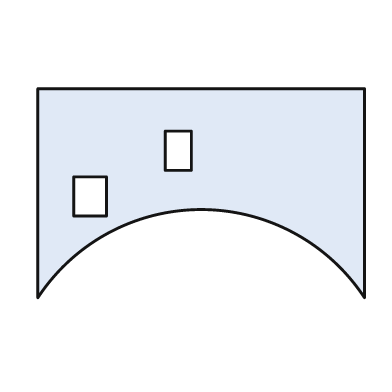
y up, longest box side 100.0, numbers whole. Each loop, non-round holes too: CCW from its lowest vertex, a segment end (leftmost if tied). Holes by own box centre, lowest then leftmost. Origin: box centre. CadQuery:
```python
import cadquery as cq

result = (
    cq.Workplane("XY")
    .moveTo(-50.0, -32.0)
    .threePointArc((0.0, -5.0), (50.0, -32.0))
    .lineTo(50.0, 32.0)
    .lineTo(-50.0, 32.0)
    .close()
    .moveTo(-39.0, -7.0)
    .lineTo(-29.0, -7.0)
    .lineTo(-29.0, 5.0)
    .lineTo(-39.0, 5.0)
    .close()
    .moveTo(-11.0, 7.0)
    .lineTo(-3.0, 7.0)
    .lineTo(-3.0, 19.0)
    .lineTo(-11.0, 19.0)
    .close()
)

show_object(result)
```